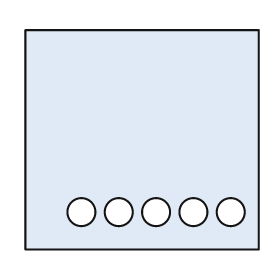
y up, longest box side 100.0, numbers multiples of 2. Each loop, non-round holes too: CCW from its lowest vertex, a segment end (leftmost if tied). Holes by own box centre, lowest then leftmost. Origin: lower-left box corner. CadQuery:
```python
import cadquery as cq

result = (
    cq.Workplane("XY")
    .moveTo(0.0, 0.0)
    .lineTo(100.0, 0.0)
    .lineTo(100.0, 94.0)
    .lineTo(0.0, 94.0)
    .close()
    .moveTo(24.0, 16.0)
    .circle(6.0)
    .moveTo(40.0, 16.0)
    .circle(6.0)
    .moveTo(56.0, 16.0)
    .circle(6.0)
    .moveTo(72.0, 16.0)
    .circle(6.0)
    .moveTo(88.0, 16.0)
    .circle(6.0)
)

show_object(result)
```